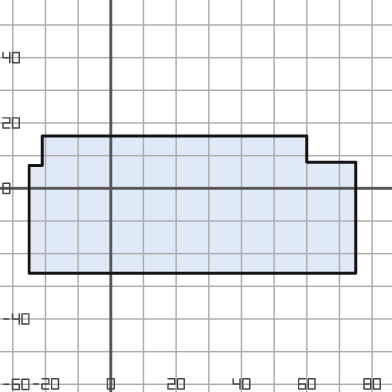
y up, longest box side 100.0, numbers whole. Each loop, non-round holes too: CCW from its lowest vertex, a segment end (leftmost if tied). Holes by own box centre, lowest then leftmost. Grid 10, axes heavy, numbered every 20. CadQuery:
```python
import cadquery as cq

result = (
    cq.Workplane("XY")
    .moveTo(-25.0, -26.0)
    .lineTo(75.0, -26.0)
    .lineTo(75.0, 8.0)
    .lineTo(60.0, 8.0)
    .lineTo(60.0, 16.0)
    .lineTo(-21.0, 16.0)
    .lineTo(-21.0, 7.0)
    .lineTo(-25.0, 7.0)
    .close()
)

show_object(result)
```